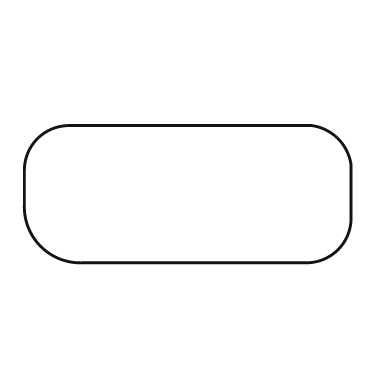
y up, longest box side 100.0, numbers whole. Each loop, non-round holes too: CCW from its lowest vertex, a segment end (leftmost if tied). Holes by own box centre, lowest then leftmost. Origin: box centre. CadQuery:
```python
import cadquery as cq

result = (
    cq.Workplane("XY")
    .moveTo(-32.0, -21.0)
    .lineTo(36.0, -21.0)
    .threePointArc((46.0, -17.0), (50.0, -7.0))
    .lineTo(50.0, 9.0)
    .threePointArc((46.0, 17.0), (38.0, 21.0))
    .lineTo(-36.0, 21.0)
    .threePointArc((-46.0, 17.0), (-50.0, 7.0))
    .lineTo(-50.0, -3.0)
    .threePointArc((-45.0, -16.0), (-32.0, -21.0))
    .close()
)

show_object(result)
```